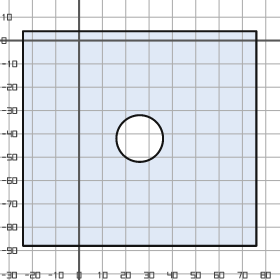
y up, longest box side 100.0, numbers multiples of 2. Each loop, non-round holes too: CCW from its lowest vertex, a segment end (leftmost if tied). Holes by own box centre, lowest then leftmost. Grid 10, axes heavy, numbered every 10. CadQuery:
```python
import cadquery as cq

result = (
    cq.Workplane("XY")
    .moveTo(-24.0, -88.0)
    .lineTo(76.0, -88.0)
    .lineTo(76.0, 4.0)
    .lineTo(-24.0, 4.0)
    .close()
    .moveTo(26.0, -42.0)
    .circle(10.0)
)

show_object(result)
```